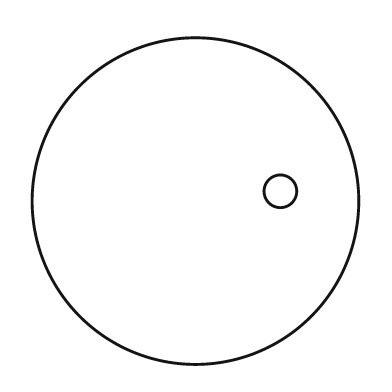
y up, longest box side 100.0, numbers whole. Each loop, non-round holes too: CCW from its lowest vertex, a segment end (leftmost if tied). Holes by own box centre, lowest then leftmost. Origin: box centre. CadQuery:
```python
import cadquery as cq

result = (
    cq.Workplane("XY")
    .moveTo(0.0, 0.0)
    .circle(50.0)
    .moveTo(26.0, 3.0)
    .circle(5.0)
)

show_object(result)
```